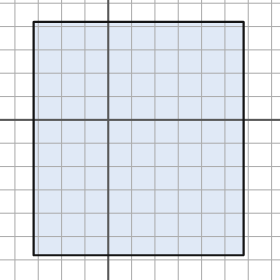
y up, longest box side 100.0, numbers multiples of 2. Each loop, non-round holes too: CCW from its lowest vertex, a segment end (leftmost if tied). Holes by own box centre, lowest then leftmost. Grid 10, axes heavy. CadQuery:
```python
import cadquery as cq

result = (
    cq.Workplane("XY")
    .moveTo(-32.0, -58.0)
    .lineTo(58.0, -58.0)
    .lineTo(58.0, 42.0)
    .lineTo(-32.0, 42.0)
    .close()
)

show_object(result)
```